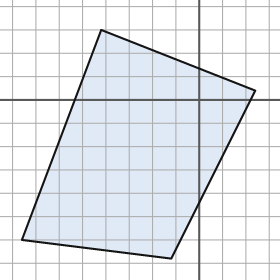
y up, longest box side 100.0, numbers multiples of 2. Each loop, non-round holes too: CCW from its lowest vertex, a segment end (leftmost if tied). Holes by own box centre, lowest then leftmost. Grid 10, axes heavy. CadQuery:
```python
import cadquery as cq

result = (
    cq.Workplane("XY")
    .moveTo(-12.0, -68.0)
    .lineTo(24.0, 4.0)
    .lineTo(-42.0, 30.0)
    .lineTo(-76.0, -60.0)
    .close()
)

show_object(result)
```